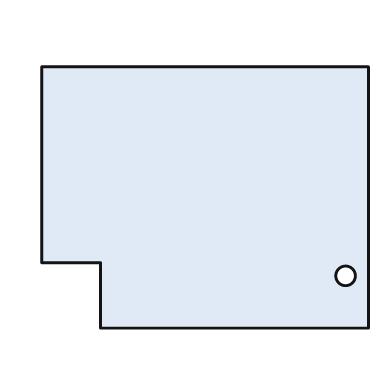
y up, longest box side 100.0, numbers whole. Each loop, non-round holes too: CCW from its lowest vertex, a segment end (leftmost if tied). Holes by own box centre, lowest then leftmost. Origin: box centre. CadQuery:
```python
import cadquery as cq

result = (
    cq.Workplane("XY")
    .moveTo(-32.0, -40.0)
    .lineTo(50.0, -40.0)
    .lineTo(50.0, 40.0)
    .lineTo(-50.0, 40.0)
    .lineTo(-50.0, -20.0)
    .lineTo(-32.0, -20.0)
    .close()
    .moveTo(43.0, -24.0)
    .circle(3.0)
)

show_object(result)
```